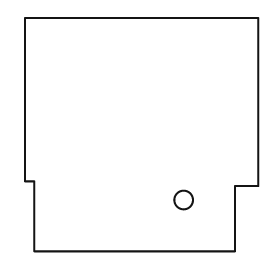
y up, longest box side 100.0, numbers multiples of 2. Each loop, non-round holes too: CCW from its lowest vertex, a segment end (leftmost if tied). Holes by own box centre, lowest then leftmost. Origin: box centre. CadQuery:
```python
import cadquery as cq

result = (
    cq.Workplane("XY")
    .moveTo(-46.0, -50.0)
    .lineTo(40.0, -50.0)
    .lineTo(40.0, -22.0)
    .lineTo(50.0, -22.0)
    .lineTo(50.0, 50.0)
    .lineTo(-50.0, 50.0)
    .lineTo(-50.0, -20.0)
    .lineTo(-46.0, -20.0)
    .close()
    .moveTo(18.0, -28.0)
    .circle(4.0)
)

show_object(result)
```